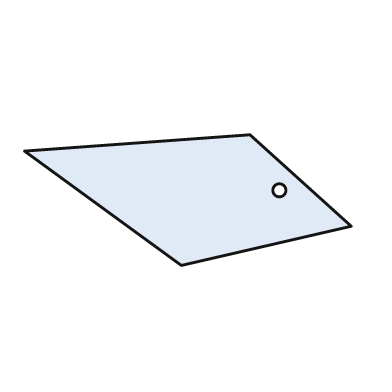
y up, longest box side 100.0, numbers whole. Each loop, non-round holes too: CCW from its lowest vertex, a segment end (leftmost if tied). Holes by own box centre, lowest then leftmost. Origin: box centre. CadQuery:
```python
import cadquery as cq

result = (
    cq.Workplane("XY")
    .moveTo(-2.0, -20.0)
    .lineTo(50.0, -8.0)
    .lineTo(19.0, 20.0)
    .lineTo(-50.0, 15.0)
    .close()
    .moveTo(28.0, 3.0)
    .circle(2.0)
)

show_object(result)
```